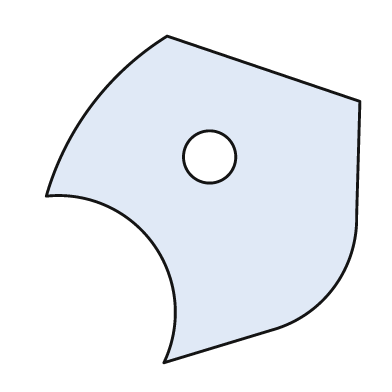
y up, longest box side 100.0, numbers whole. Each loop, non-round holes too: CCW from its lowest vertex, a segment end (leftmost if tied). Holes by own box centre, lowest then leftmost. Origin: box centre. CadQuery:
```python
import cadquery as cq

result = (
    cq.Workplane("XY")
    .moveTo(-12.0, -50.0)
    .lineTo(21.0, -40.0)
    .threePointArc((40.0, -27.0), (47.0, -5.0))
    .lineTo(48.0, 30.0)
    .lineTo(-11.0, 50.0)
    .threePointArc((-34.0, 29.0), (-48.0, 1.0))
    .threePointArc((-15.0, -14.0), (-12.0, -50.0))
    .close()
    .moveTo(2.0, 13.0)
    .circle(8.0)
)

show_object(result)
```